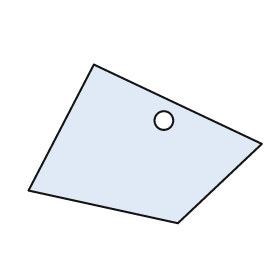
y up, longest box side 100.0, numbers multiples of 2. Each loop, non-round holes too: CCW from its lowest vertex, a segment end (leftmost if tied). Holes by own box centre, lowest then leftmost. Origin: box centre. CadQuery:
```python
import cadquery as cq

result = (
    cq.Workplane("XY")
    .moveTo(14.0, -34.0)
    .lineTo(50.0, 0.0)
    .lineTo(-22.0, 34.0)
    .lineTo(-50.0, -20.0)
    .close()
    .moveTo(8.0, 10.0)
    .circle(4.0)
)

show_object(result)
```